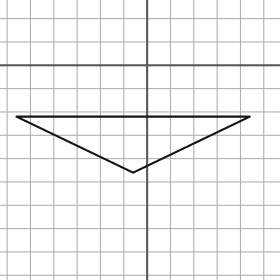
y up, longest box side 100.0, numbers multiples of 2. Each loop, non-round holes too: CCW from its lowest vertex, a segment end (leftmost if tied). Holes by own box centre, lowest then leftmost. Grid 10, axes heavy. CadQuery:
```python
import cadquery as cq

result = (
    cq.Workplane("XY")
    .moveTo(-6.0, -46.0)
    .lineTo(44.0, -22.0)
    .lineTo(-56.0, -22.0)
    .close()
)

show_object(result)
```